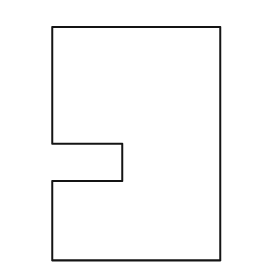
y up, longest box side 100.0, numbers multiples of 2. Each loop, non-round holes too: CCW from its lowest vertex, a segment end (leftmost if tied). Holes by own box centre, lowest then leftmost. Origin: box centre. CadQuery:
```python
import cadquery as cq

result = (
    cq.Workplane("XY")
    .moveTo(-36.0, -50.0)
    .lineTo(36.0, -50.0)
    .lineTo(36.0, 50.0)
    .lineTo(-36.0, 50.0)
    .lineTo(-36.0, 0.0)
    .lineTo(-6.0, 0.0)
    .lineTo(-6.0, -16.0)
    .lineTo(-36.0, -16.0)
    .close()
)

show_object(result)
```